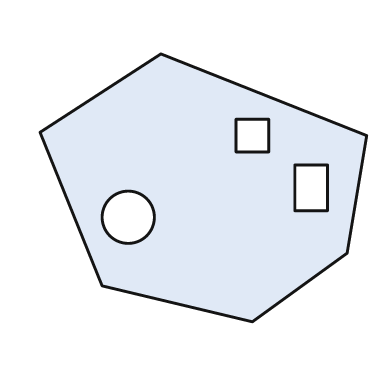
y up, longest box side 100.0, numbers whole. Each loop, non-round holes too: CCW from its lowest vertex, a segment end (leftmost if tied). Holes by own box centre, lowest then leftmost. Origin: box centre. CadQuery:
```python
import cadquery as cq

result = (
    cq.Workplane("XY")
    .moveTo(15.0, -41.0)
    .lineTo(44.0, -20.0)
    .lineTo(50.0, 16.0)
    .lineTo(-13.0, 41.0)
    .lineTo(-50.0, 17.0)
    .lineTo(-31.0, -30.0)
    .close()
    .moveTo(-23.0, -9.0)
    .circle(8.0)
    .moveTo(28.0, -7.0)
    .lineTo(38.0, -7.0)
    .lineTo(38.0, 7.0)
    .lineTo(28.0, 7.0)
    .close()
    .moveTo(10.0, 11.0)
    .lineTo(20.0, 11.0)
    .lineTo(20.0, 21.0)
    .lineTo(10.0, 21.0)
    .close()
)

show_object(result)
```